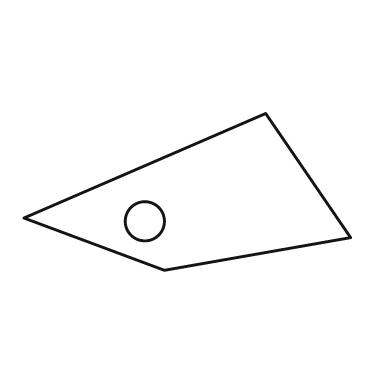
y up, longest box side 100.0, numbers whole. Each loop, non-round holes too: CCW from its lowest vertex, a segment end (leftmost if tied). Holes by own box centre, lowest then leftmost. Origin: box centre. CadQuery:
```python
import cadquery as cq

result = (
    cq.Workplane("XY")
    .moveTo(-7.0, -24.0)
    .lineTo(50.0, -14.0)
    .lineTo(24.0, 24.0)
    .lineTo(-50.0, -8.0)
    .close()
    .moveTo(-13.0, -9.0)
    .circle(6.0)
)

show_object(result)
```